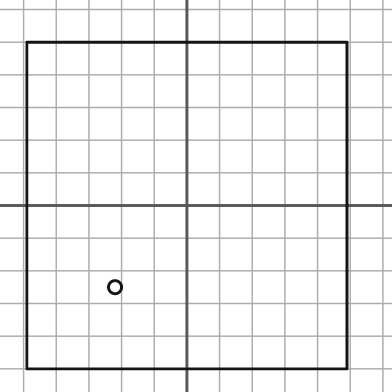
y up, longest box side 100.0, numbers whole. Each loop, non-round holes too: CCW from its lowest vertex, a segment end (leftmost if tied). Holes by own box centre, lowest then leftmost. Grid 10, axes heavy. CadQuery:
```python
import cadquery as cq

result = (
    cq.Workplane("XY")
    .moveTo(-49.0, -50.0)
    .lineTo(49.0, -50.0)
    .lineTo(49.0, 50.0)
    .lineTo(-49.0, 50.0)
    .close()
    .moveTo(-22.0, -25.0)
    .circle(2.0)
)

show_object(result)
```